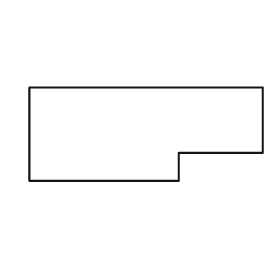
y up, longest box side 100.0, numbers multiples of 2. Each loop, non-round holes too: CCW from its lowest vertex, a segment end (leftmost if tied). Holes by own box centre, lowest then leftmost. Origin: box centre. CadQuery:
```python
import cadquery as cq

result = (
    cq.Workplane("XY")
    .moveTo(-50.0, -20.0)
    .lineTo(14.0, -20.0)
    .lineTo(14.0, -8.0)
    .lineTo(50.0, -8.0)
    .lineTo(50.0, 20.0)
    .lineTo(-50.0, 20.0)
    .close()
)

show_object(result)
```